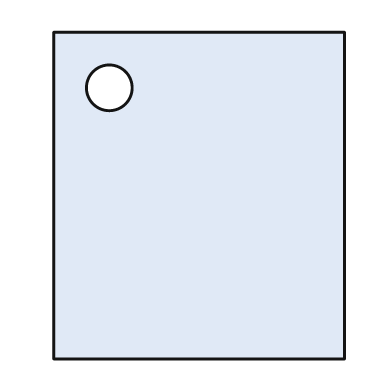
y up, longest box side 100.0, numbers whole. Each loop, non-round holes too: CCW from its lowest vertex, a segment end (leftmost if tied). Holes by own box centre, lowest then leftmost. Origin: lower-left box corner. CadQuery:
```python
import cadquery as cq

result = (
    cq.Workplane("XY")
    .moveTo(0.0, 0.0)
    .lineTo(89.0, 0.0)
    .lineTo(89.0, 100.0)
    .lineTo(0.0, 100.0)
    .close()
    .moveTo(17.0, 83.0)
    .circle(7.0)
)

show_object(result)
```